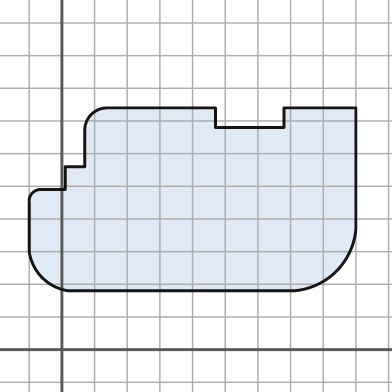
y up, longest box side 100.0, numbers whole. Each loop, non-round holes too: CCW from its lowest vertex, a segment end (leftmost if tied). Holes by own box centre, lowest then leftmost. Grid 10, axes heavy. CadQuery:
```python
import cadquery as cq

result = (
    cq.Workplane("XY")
    .moveTo(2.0, 18.0)
    .lineTo(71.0, 18.0)
    .threePointArc((84.0, 24.0), (90.0, 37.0))
    .lineTo(90.0, 74.0)
    .lineTo(68.0, 74.0)
    .lineTo(68.0, 68.0)
    .lineTo(47.0, 68.0)
    .lineTo(47.0, 74.0)
    .lineTo(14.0, 74.0)
    .threePointArc((9.0, 72.0), (7.0, 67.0))
    .lineTo(7.0, 56.0)
    .lineTo(1.0, 56.0)
    .lineTo(1.0, 49.0)
    .lineTo(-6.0, 49.0)
    .threePointArc((-9.0, 48.0), (-10.0, 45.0))
    .lineTo(-10.0, 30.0)
    .threePointArc((-6.0, 22.0), (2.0, 18.0))
    .close()
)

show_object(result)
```